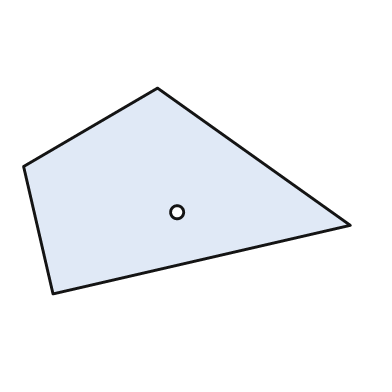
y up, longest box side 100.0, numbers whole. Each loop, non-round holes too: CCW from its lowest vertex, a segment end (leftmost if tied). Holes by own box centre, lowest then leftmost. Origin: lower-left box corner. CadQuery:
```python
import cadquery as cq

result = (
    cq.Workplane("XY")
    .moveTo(9.0, 0.0)
    .lineTo(100.0, 21.0)
    .lineTo(41.0, 63.0)
    .lineTo(0.0, 39.0)
    .close()
    .moveTo(47.0, 25.0)
    .circle(2.0)
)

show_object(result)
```